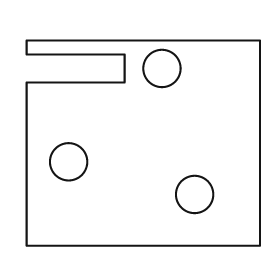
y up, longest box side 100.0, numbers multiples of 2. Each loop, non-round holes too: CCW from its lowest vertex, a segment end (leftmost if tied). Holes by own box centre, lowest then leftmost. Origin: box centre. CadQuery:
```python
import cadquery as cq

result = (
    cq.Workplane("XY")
    .moveTo(-50.0, -44.0)
    .lineTo(50.0, -44.0)
    .lineTo(50.0, 44.0)
    .lineTo(-50.0, 44.0)
    .lineTo(-50.0, 38.0)
    .lineTo(-8.0, 38.0)
    .lineTo(-8.0, 26.0)
    .lineTo(-50.0, 26.0)
    .close()
    .moveTo(22.0, -22.0)
    .circle(8.0)
    .moveTo(-32.0, -8.0)
    .circle(8.0)
    .moveTo(8.0, 32.0)
    .circle(8.0)
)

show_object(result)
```